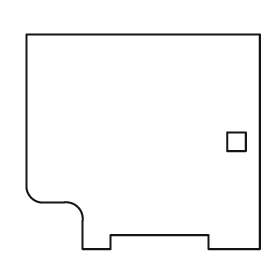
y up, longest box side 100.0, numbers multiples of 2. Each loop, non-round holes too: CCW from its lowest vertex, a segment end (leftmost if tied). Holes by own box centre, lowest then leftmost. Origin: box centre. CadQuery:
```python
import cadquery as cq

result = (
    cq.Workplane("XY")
    .moveTo(-26.0, -46.0)
    .lineTo(-14.0, -46.0)
    .lineTo(-14.0, -40.0)
    .lineTo(28.0, -40.0)
    .lineTo(28.0, -46.0)
    .lineTo(50.0, -46.0)
    .lineTo(50.0, 46.0)
    .lineTo(-50.0, 46.0)
    .lineTo(-50.0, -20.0)
    .threePointArc((-48.0, -24.0), (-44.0, -26.0))
    .lineTo(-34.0, -26.0)
    .threePointArc((-28.0, -28.0), (-26.0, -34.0))
    .close()
    .moveTo(36.0, -4.0)
    .lineTo(44.0, -4.0)
    .lineTo(44.0, 4.0)
    .lineTo(36.0, 4.0)
    .close()
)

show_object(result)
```